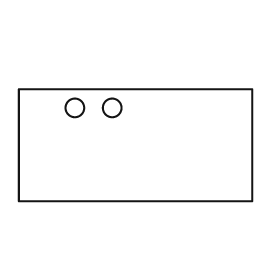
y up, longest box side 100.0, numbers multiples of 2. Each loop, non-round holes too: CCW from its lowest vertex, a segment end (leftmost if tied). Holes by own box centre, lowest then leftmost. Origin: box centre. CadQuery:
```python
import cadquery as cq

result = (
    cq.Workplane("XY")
    .moveTo(-50.0, -24.0)
    .lineTo(50.0, -24.0)
    .lineTo(50.0, 24.0)
    .lineTo(-50.0, 24.0)
    .close()
    .moveTo(-26.0, 16.0)
    .circle(4.0)
    .moveTo(-10.0, 16.0)
    .circle(4.0)
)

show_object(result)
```